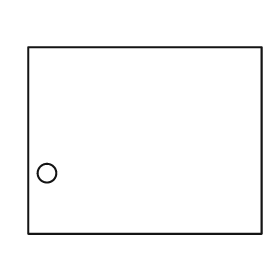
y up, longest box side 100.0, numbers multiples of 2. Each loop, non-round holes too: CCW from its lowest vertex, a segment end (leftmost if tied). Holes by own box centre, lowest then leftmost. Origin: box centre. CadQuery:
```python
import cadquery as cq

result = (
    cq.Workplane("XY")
    .moveTo(-50.0, -40.0)
    .lineTo(50.0, -40.0)
    .lineTo(50.0, 40.0)
    .lineTo(-50.0, 40.0)
    .close()
    .moveTo(-42.0, -14.0)
    .circle(4.0)
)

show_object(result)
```